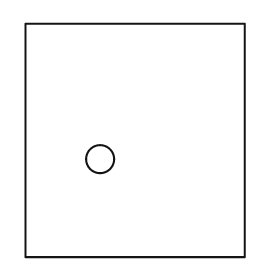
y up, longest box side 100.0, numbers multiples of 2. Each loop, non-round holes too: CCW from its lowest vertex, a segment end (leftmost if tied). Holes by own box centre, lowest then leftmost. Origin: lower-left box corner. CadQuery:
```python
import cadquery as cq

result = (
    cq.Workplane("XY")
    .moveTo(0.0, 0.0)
    .lineTo(94.0, 0.0)
    .lineTo(94.0, 100.0)
    .lineTo(0.0, 100.0)
    .close()
    .moveTo(32.0, 42.0)
    .circle(6.0)
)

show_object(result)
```